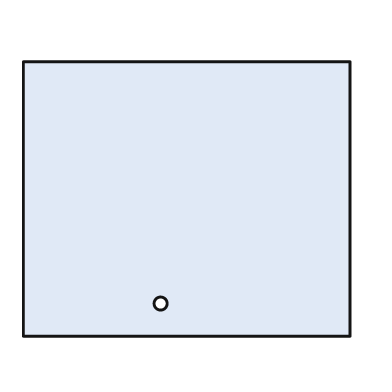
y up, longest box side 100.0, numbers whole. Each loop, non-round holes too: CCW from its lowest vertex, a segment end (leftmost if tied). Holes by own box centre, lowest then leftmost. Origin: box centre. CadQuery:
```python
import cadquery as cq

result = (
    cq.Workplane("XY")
    .moveTo(-50.0, -42.0)
    .lineTo(50.0, -42.0)
    .lineTo(50.0, 42.0)
    .lineTo(-50.0, 42.0)
    .close()
    .moveTo(-8.0, -32.0)
    .circle(2.0)
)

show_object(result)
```